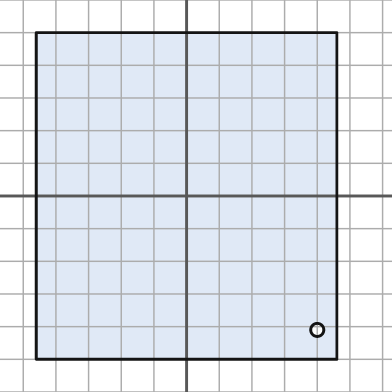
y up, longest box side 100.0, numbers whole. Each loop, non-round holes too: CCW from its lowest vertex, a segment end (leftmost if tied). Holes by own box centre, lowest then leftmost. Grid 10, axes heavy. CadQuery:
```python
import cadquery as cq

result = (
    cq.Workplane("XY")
    .moveTo(-46.0, -50.0)
    .lineTo(46.0, -50.0)
    .lineTo(46.0, 50.0)
    .lineTo(-46.0, 50.0)
    .close()
    .moveTo(40.0, -41.0)
    .circle(2.0)
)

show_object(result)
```